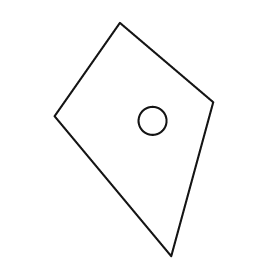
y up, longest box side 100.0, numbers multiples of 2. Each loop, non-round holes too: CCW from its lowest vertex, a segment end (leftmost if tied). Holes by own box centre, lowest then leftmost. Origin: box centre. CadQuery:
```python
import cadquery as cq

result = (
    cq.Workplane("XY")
    .moveTo(16.0, -50.0)
    .lineTo(34.0, 16.0)
    .lineTo(-6.0, 50.0)
    .lineTo(-34.0, 10.0)
    .close()
    .moveTo(8.0, 8.0)
    .circle(6.0)
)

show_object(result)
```